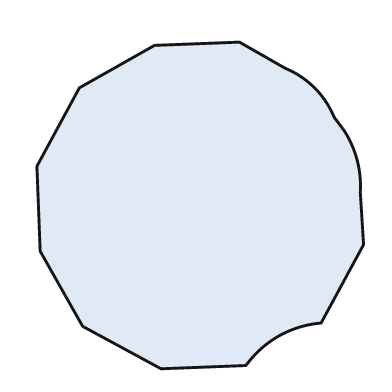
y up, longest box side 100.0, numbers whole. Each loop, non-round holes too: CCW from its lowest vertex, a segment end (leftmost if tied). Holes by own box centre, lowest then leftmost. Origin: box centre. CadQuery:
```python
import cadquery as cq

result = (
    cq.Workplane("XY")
    .moveTo(-12.0, -50.0)
    .lineTo(14.0, -49.0)
    .threePointArc((24.0, -40.0), (37.0, -36.0))
    .lineTo(50.0, -12.0)
    .lineTo(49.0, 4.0)
    .threePointArc((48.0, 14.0), (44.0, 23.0))
    .lineTo(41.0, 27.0)
    .threePointArc((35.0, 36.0), (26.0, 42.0))
    .lineTo(12.0, 50.0)
    .lineTo(-14.0, 49.0)
    .lineTo(-37.0, 36.0)
    .lineTo(-50.0, 12.0)
    .lineTo(-49.0, -14.0)
    .lineTo(-36.0, -37.0)
    .close()
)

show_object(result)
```